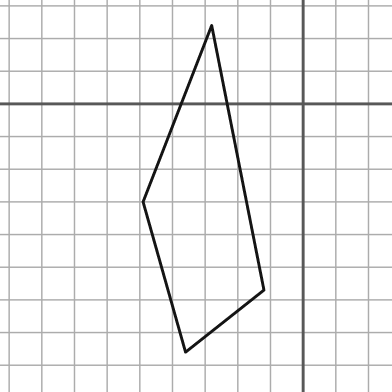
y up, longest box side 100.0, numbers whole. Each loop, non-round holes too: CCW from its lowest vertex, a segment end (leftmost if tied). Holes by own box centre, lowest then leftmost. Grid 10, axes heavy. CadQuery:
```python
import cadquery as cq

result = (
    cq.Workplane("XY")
    .moveTo(-36.0, -76.0)
    .lineTo(-12.0, -57.0)
    .lineTo(-28.0, 24.0)
    .lineTo(-49.0, -30.0)
    .close()
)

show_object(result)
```